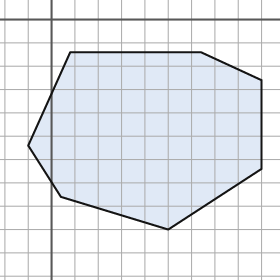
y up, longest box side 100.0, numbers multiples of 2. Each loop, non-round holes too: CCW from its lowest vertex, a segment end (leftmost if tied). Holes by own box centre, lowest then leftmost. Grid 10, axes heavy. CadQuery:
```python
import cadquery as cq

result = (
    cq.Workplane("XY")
    .moveTo(50.0, -90.0)
    .lineTo(90.0, -64.0)
    .lineTo(90.0, -26.0)
    .lineTo(64.0, -14.0)
    .lineTo(8.0, -14.0)
    .lineTo(-10.0, -54.0)
    .lineTo(4.0, -76.0)
    .close()
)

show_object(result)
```